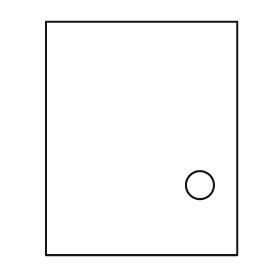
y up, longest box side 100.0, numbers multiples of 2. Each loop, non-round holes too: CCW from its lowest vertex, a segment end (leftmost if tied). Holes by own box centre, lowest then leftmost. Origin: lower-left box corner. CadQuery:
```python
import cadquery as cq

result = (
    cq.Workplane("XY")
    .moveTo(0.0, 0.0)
    .lineTo(82.0, 0.0)
    .lineTo(82.0, 100.0)
    .lineTo(0.0, 100.0)
    .close()
    .moveTo(66.0, 30.0)
    .circle(6.0)
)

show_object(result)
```